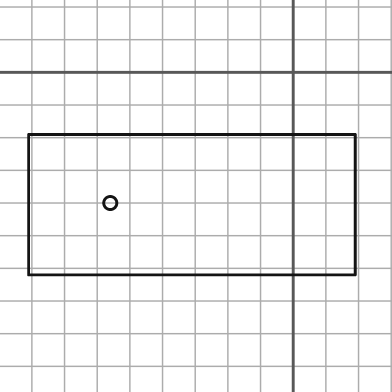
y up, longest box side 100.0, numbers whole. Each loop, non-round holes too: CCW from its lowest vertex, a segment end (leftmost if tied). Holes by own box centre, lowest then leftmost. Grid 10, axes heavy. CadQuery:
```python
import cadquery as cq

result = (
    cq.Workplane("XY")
    .moveTo(-81.0, -62.0)
    .lineTo(19.0, -62.0)
    .lineTo(19.0, -19.0)
    .lineTo(-81.0, -19.0)
    .close()
    .moveTo(-56.0, -40.0)
    .circle(2.0)
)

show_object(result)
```